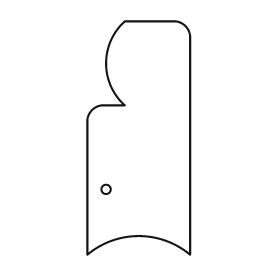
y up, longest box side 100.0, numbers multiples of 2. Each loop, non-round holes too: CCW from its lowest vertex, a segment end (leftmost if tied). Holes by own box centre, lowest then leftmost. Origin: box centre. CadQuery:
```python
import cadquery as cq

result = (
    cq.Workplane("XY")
    .moveTo(-22.0, -50.0)
    .threePointArc((0.0, -42.0), (22.0, -50.0))
    .lineTo(22.0, 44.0)
    .threePointArc((20.0, 48.0), (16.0, 50.0))
    .lineTo(-6.0, 50.0)
    .threePointArc((-14.0, 32.0), (-6.0, 14.0))
    .lineTo(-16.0, 14.0)
    .threePointArc((-20.0, 12.0), (-22.0, 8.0))
    .close()
    .moveTo(-14.0, -22.0)
    .circle(2.0)
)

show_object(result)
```